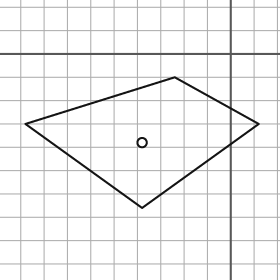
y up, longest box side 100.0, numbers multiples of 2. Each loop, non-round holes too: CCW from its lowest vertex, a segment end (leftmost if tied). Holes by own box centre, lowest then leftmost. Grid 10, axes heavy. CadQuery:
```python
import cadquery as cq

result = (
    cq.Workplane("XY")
    .moveTo(-38.0, -66.0)
    .lineTo(12.0, -30.0)
    .lineTo(-24.0, -10.0)
    .lineTo(-88.0, -30.0)
    .close()
    .moveTo(-38.0, -38.0)
    .circle(2.0)
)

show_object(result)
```